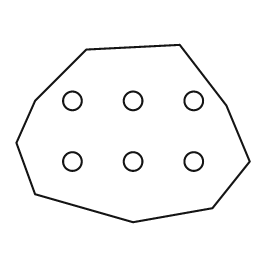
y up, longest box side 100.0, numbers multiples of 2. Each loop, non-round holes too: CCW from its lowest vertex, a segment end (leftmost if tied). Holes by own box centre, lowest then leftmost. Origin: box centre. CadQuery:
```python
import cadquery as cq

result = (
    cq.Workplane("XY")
    .moveTo(0.0, -38.0)
    .lineTo(34.0, -32.0)
    .lineTo(50.0, -12.0)
    .lineTo(40.0, 12.0)
    .lineTo(20.0, 38.0)
    .lineTo(-20.0, 36.0)
    .lineTo(-42.0, 14.0)
    .lineTo(-50.0, -4.0)
    .lineTo(-42.0, -26.0)
    .close()
    .moveTo(-26.0, -12.0)
    .circle(4.0)
    .moveTo(0.0, -12.0)
    .circle(4.0)
    .moveTo(26.0, -12.0)
    .circle(4.0)
    .moveTo(-26.0, 14.0)
    .circle(4.0)
    .moveTo(0.0, 14.0)
    .circle(4.0)
    .moveTo(26.0, 14.0)
    .circle(4.0)
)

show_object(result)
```